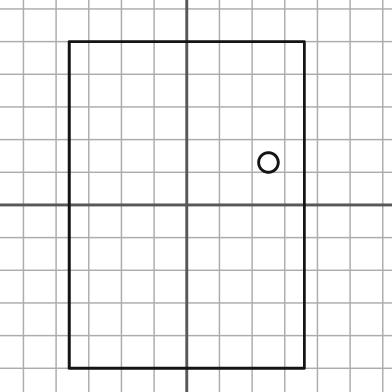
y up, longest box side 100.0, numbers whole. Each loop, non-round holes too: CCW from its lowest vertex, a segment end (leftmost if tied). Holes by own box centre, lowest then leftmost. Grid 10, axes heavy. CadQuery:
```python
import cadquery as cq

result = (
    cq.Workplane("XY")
    .moveTo(-36.0, -50.0)
    .lineTo(36.0, -50.0)
    .lineTo(36.0, 50.0)
    .lineTo(-36.0, 50.0)
    .close()
    .moveTo(25.0, 13.0)
    .circle(3.0)
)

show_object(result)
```